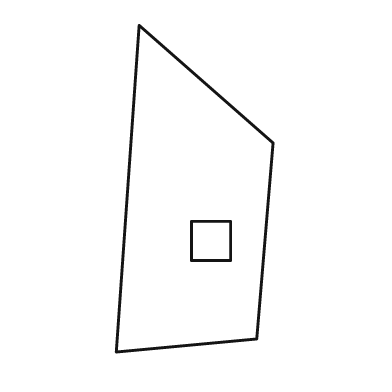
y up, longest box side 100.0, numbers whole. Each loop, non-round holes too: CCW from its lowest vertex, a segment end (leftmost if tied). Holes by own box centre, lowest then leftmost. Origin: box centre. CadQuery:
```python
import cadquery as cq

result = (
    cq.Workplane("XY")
    .moveTo(-24.0, -50.0)
    .lineTo(19.0, -46.0)
    .lineTo(24.0, 14.0)
    .lineTo(-17.0, 50.0)
    .close()
    .moveTo(-1.0, -22.0)
    .lineTo(11.0, -22.0)
    .lineTo(11.0, -10.0)
    .lineTo(-1.0, -10.0)
    .close()
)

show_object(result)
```